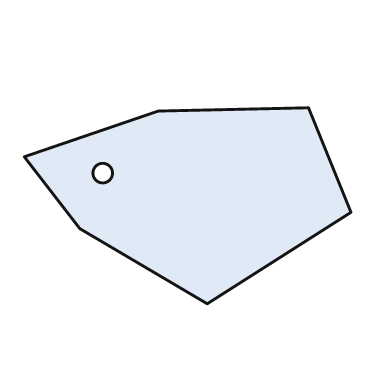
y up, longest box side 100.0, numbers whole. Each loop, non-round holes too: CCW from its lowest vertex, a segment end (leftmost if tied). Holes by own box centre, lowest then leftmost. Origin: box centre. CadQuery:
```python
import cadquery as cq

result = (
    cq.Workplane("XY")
    .moveTo(6.0, -30.0)
    .lineTo(50.0, -2.0)
    .lineTo(37.0, 30.0)
    .lineTo(-9.0, 29.0)
    .lineTo(-50.0, 15.0)
    .lineTo(-33.0, -7.0)
    .close()
    .moveTo(-26.0, 10.0)
    .circle(3.0)
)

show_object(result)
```